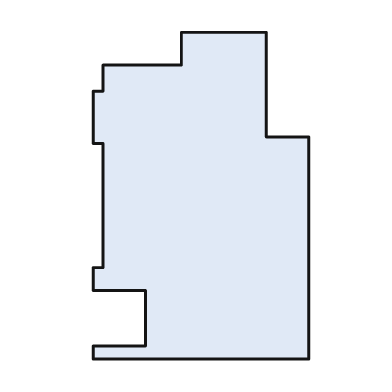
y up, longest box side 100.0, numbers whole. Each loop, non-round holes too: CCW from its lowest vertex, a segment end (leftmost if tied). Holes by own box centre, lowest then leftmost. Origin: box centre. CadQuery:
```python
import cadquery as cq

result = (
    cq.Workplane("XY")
    .moveTo(-33.0, -50.0)
    .lineTo(33.0, -50.0)
    .lineTo(33.0, 18.0)
    .lineTo(20.0, 18.0)
    .lineTo(20.0, 50.0)
    .lineTo(-6.0, 50.0)
    .lineTo(-6.0, 40.0)
    .lineTo(-30.0, 40.0)
    .lineTo(-30.0, 32.0)
    .lineTo(-33.0, 32.0)
    .lineTo(-33.0, 16.0)
    .lineTo(-30.0, 16.0)
    .lineTo(-30.0, -22.0)
    .lineTo(-33.0, -22.0)
    .lineTo(-33.0, -29.0)
    .lineTo(-17.0, -29.0)
    .lineTo(-17.0, -46.0)
    .lineTo(-33.0, -46.0)
    .close()
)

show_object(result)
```